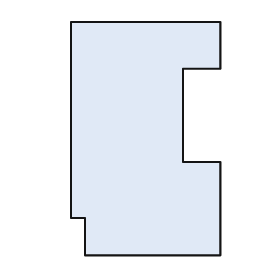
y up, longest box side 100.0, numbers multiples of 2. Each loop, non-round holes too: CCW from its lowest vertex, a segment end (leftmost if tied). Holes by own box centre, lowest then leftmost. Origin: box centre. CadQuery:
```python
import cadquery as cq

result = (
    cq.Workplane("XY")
    .moveTo(-26.0, -50.0)
    .lineTo(32.0, -50.0)
    .lineTo(32.0, -10.0)
    .lineTo(16.0, -10.0)
    .lineTo(16.0, 30.0)
    .lineTo(32.0, 30.0)
    .lineTo(32.0, 50.0)
    .lineTo(-32.0, 50.0)
    .lineTo(-32.0, -34.0)
    .lineTo(-26.0, -34.0)
    .close()
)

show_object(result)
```